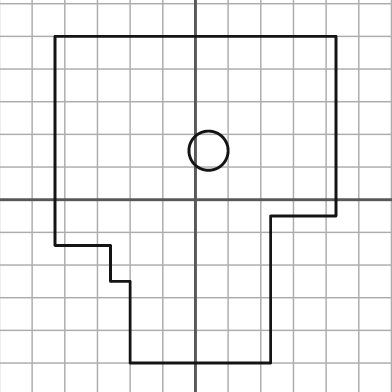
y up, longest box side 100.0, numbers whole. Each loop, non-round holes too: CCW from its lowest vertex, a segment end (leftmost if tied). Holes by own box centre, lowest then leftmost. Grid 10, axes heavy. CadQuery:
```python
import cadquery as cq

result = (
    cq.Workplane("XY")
    .moveTo(-20.0, -50.0)
    .lineTo(23.0, -50.0)
    .lineTo(23.0, -5.0)
    .lineTo(43.0, -5.0)
    .lineTo(43.0, 50.0)
    .lineTo(-43.0, 50.0)
    .lineTo(-43.0, -14.0)
    .lineTo(-26.0, -14.0)
    .lineTo(-26.0, -25.0)
    .lineTo(-20.0, -25.0)
    .close()
    .moveTo(4.0, 15.0)
    .circle(6.0)
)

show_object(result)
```